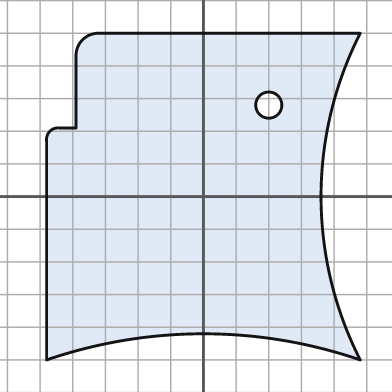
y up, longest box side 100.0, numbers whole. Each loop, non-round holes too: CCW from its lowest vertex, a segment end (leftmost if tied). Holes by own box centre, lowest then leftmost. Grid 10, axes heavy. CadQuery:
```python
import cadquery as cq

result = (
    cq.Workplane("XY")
    .moveTo(-48.0, -50.0)
    .threePointArc((0.0, -42.0), (48.0, -50.0))
    .threePointArc((36.0, 0.0), (48.0, 50.0))
    .lineTo(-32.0, 50.0)
    .threePointArc((-37.0, 48.0), (-39.0, 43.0))
    .lineTo(-39.0, 21.0)
    .lineTo(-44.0, 21.0)
    .threePointArc((-47.0, 20.0), (-48.0, 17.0))
    .close()
    .moveTo(20.0, 28.0)
    .circle(4.0)
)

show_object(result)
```